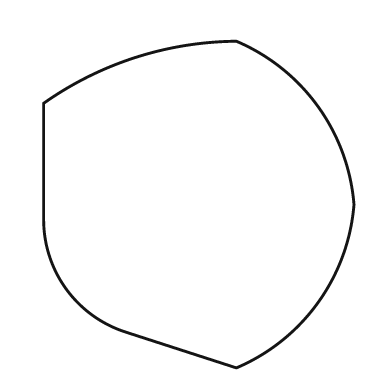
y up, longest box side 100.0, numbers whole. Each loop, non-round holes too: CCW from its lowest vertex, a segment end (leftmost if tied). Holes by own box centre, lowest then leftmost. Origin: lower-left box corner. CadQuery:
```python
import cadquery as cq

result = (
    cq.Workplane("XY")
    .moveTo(59.0, 0.0)
    .threePointArc((84.0, 20.0), (95.0, 50.0))
    .threePointArc((84.0, 80.0), (59.0, 100.0))
    .threePointArc((28.0, 95.0), (0.0, 81.0))
    .lineTo(0.0, 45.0)
    .threePointArc((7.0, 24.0), (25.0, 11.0))
    .close()
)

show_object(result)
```